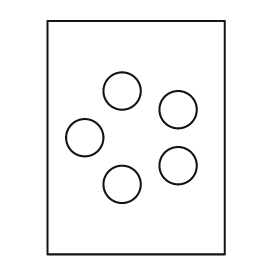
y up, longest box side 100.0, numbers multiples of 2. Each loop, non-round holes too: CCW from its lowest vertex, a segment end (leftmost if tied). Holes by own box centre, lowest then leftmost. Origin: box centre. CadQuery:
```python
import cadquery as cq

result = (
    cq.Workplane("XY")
    .moveTo(-38.0, -50.0)
    .lineTo(38.0, -50.0)
    .lineTo(38.0, 50.0)
    .lineTo(-38.0, 50.0)
    .close()
    .moveTo(-6.0, -20.0)
    .circle(8.0)
    .moveTo(18.0, -12.0)
    .circle(8.0)
    .moveTo(-22.0, 0.0)
    .circle(8.0)
    .moveTo(18.0, 12.0)
    .circle(8.0)
    .moveTo(-6.0, 20.0)
    .circle(8.0)
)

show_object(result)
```